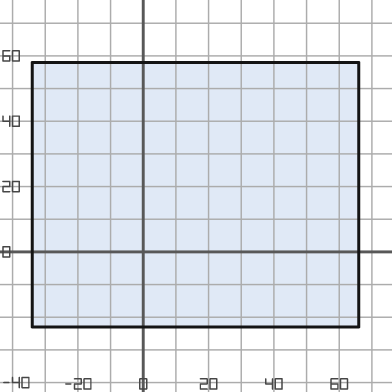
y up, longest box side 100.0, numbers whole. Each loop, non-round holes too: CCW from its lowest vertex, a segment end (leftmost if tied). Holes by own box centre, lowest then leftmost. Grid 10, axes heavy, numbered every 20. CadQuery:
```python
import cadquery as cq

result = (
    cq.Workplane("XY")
    .moveTo(-34.0, -23.0)
    .lineTo(66.0, -23.0)
    .lineTo(66.0, 58.0)
    .lineTo(-34.0, 58.0)
    .close()
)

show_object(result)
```